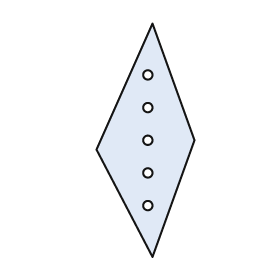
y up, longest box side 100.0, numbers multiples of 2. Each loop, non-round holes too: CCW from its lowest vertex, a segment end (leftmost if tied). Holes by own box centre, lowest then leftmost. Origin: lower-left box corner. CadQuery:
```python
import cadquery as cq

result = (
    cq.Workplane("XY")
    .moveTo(24.0, 0.0)
    .lineTo(42.0, 50.0)
    .lineTo(24.0, 100.0)
    .lineTo(0.0, 46.0)
    .close()
    .moveTo(22.0, 22.0)
    .circle(2.0)
    .moveTo(22.0, 36.0)
    .circle(2.0)
    .moveTo(22.0, 50.0)
    .circle(2.0)
    .moveTo(22.0, 64.0)
    .circle(2.0)
    .moveTo(22.0, 78.0)
    .circle(2.0)
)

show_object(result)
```